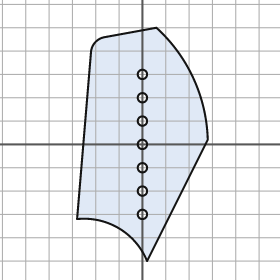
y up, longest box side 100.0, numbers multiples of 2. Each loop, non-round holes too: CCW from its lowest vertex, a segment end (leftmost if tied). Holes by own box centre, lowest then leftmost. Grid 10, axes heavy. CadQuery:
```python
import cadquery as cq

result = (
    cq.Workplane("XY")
    .moveTo(2.0, -50.0)
    .lineTo(28.0, 2.0)
    .threePointArc((22.0, 28.0), (6.0, 50.0))
    .lineTo(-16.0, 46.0)
    .threePointArc((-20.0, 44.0), (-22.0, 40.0))
    .lineTo(-28.0, -32.0)
    .threePointArc((-10.0, -36.0), (2.0, -50.0))
    .close()
    .moveTo(0.0, -30.0)
    .circle(2.0)
    .moveTo(0.0, -20.0)
    .circle(2.0)
    .moveTo(0.0, -10.0)
    .circle(2.0)
    .moveTo(0.0, 0.0)
    .circle(2.0)
    .moveTo(0.0, 10.0)
    .circle(2.0)
    .moveTo(0.0, 20.0)
    .circle(2.0)
    .moveTo(0.0, 30.0)
    .circle(2.0)
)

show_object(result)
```